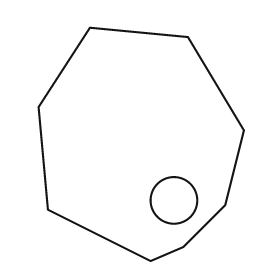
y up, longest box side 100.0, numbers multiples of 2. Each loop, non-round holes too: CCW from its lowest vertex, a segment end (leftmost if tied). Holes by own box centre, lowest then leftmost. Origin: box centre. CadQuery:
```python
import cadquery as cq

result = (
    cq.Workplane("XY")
    .moveTo(4.0, -50.0)
    .lineTo(18.0, -44.0)
    .lineTo(36.0, -26.0)
    .lineTo(44.0, 6.0)
    .lineTo(20.0, 46.0)
    .lineTo(-22.0, 50.0)
    .lineTo(-44.0, 16.0)
    .lineTo(-40.0, -28.0)
    .close()
    .moveTo(14.0, -24.0)
    .circle(10.0)
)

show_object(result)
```